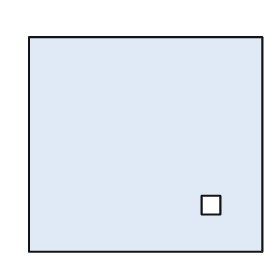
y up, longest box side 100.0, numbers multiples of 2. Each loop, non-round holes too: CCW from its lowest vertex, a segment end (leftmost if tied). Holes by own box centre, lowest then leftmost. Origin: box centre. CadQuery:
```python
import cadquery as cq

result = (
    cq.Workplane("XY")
    .moveTo(-50.0, -46.0)
    .lineTo(50.0, -46.0)
    .lineTo(50.0, 46.0)
    .lineTo(-50.0, 46.0)
    .close()
    .moveTo(24.0, -30.0)
    .lineTo(32.0, -30.0)
    .lineTo(32.0, -22.0)
    .lineTo(24.0, -22.0)
    .close()
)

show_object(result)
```